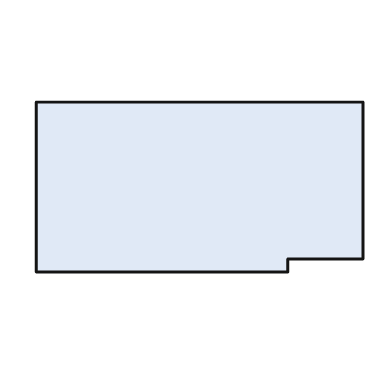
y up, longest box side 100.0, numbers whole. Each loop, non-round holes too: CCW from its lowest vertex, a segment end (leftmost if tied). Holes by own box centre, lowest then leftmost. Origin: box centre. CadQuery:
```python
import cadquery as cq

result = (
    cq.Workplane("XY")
    .moveTo(-50.0, -26.0)
    .lineTo(27.0, -26.0)
    .lineTo(27.0, -22.0)
    .lineTo(50.0, -22.0)
    .lineTo(50.0, 26.0)
    .lineTo(-50.0, 26.0)
    .close()
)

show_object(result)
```